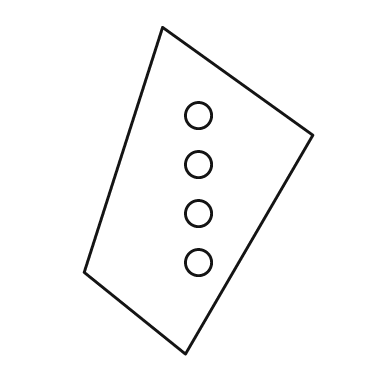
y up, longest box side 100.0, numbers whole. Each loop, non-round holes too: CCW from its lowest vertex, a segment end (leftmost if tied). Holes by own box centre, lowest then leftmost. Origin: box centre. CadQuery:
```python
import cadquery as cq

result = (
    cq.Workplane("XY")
    .moveTo(-4.0, -50.0)
    .lineTo(35.0, 17.0)
    .lineTo(-11.0, 50.0)
    .lineTo(-35.0, -25.0)
    .close()
    .moveTo(0.0, -22.0)
    .circle(4.0)
    .moveTo(0.0, -7.0)
    .circle(4.0)
    .moveTo(0.0, 8.0)
    .circle(4.0)
    .moveTo(0.0, 23.0)
    .circle(4.0)
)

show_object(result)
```